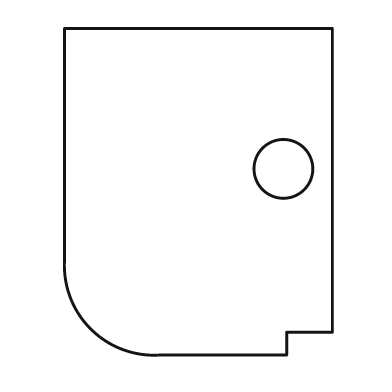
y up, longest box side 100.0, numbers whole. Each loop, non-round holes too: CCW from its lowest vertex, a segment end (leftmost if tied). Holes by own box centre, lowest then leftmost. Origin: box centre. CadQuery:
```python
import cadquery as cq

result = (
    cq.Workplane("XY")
    .moveTo(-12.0, -50.0)
    .lineTo(27.0, -50.0)
    .lineTo(27.0, -43.0)
    .lineTo(41.0, -43.0)
    .lineTo(41.0, 50.0)
    .lineTo(-41.0, 50.0)
    .lineTo(-41.0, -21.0)
    .threePointArc((-33.0, -42.0), (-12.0, -50.0))
    .close()
    .moveTo(26.0, 7.0)
    .circle(9.0)
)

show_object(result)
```